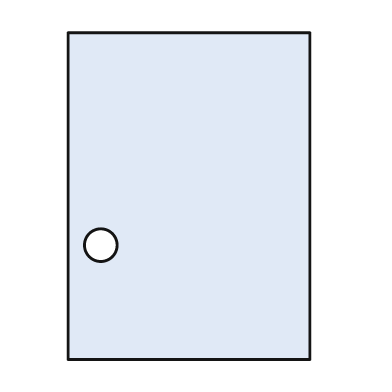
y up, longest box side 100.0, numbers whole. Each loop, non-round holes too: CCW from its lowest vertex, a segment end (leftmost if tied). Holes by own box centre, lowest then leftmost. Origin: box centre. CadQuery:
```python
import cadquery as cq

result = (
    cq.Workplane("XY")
    .moveTo(-37.0, -50.0)
    .lineTo(37.0, -50.0)
    .lineTo(37.0, 50.0)
    .lineTo(-37.0, 50.0)
    .close()
    .moveTo(-27.0, -15.0)
    .circle(5.0)
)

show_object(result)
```